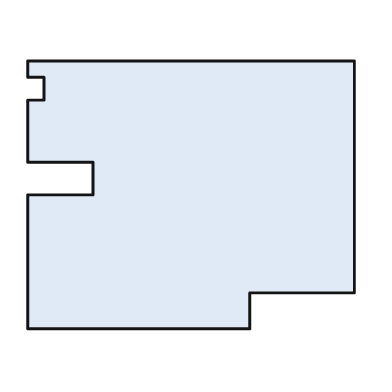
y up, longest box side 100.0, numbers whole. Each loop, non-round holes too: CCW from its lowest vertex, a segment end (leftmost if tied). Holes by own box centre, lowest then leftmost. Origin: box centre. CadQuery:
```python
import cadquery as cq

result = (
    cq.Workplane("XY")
    .moveTo(-50.0, -41.0)
    .lineTo(18.0, -41.0)
    .lineTo(18.0, -30.0)
    .lineTo(50.0, -30.0)
    .lineTo(50.0, 41.0)
    .lineTo(-50.0, 41.0)
    .lineTo(-50.0, 36.0)
    .lineTo(-45.0, 36.0)
    .lineTo(-45.0, 29.0)
    .lineTo(-50.0, 29.0)
    .lineTo(-50.0, 10.0)
    .lineTo(-30.0, 10.0)
    .lineTo(-30.0, 0.0)
    .lineTo(-50.0, 0.0)
    .close()
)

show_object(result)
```